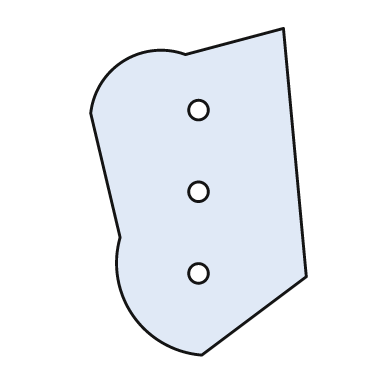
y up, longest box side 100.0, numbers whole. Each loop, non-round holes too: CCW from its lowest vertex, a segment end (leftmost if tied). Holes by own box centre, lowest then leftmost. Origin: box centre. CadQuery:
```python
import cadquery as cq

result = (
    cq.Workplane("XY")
    .moveTo(1.0, -50.0)
    .lineTo(33.0, -26.0)
    .lineTo(26.0, 50.0)
    .lineTo(-4.0, 42.0)
    .threePointArc((-23.0, 40.0), (-33.0, 24.0))
    .lineTo(-24.0, -14.0)
    .threePointArc((-20.0, -38.0), (1.0, -50.0))
    .close()
    .moveTo(0.0, -25.0)
    .circle(3.0)
    .moveTo(0.0, 0.0)
    .circle(3.0)
    .moveTo(0.0, 25.0)
    .circle(3.0)
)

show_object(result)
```